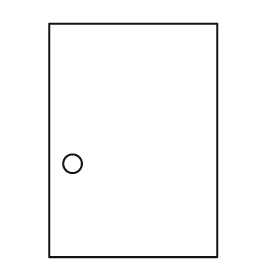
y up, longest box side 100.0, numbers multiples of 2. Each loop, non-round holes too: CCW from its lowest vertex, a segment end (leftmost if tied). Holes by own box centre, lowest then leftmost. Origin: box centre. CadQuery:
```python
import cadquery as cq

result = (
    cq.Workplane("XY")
    .moveTo(-36.0, -50.0)
    .lineTo(36.0, -50.0)
    .lineTo(36.0, 50.0)
    .lineTo(-36.0, 50.0)
    .close()
    .moveTo(-26.0, -10.0)
    .circle(4.0)
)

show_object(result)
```